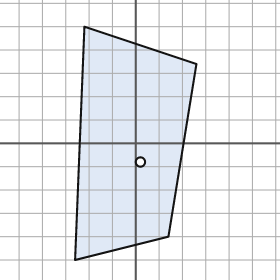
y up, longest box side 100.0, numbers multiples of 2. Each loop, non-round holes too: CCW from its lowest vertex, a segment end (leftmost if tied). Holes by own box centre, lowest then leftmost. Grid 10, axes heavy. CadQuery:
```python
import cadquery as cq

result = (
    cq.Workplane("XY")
    .moveTo(-26.0, -50.0)
    .lineTo(14.0, -40.0)
    .lineTo(26.0, 34.0)
    .lineTo(-22.0, 50.0)
    .close()
    .moveTo(2.0, -8.0)
    .circle(2.0)
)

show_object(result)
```